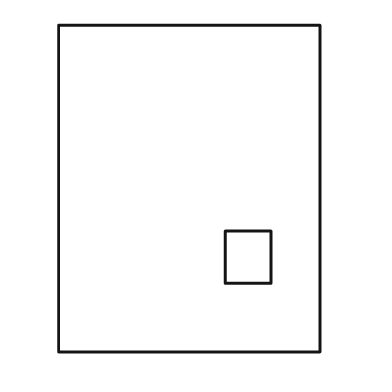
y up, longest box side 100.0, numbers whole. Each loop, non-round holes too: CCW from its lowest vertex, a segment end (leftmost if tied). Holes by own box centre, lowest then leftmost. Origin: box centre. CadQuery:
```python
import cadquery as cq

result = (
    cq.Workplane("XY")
    .moveTo(-40.0, -50.0)
    .lineTo(40.0, -50.0)
    .lineTo(40.0, 50.0)
    .lineTo(-40.0, 50.0)
    .close()
    .moveTo(11.0, -29.0)
    .lineTo(25.0, -29.0)
    .lineTo(25.0, -13.0)
    .lineTo(11.0, -13.0)
    .close()
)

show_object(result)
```